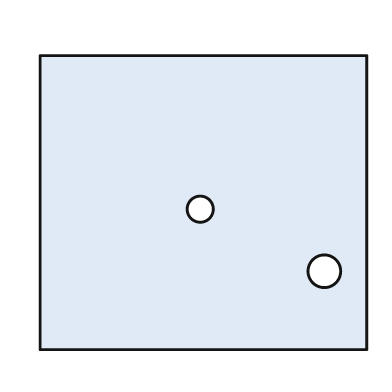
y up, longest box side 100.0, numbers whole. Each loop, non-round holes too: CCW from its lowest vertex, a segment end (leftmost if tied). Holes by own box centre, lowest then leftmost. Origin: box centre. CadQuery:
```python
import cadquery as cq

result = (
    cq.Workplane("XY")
    .moveTo(-50.0, -45.0)
    .lineTo(50.0, -45.0)
    .lineTo(50.0, 45.0)
    .lineTo(-50.0, 45.0)
    .close()
    .moveTo(37.0, -21.0)
    .circle(5.0)
    .moveTo(-1.0, -2.0)
    .circle(4.0)
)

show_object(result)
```